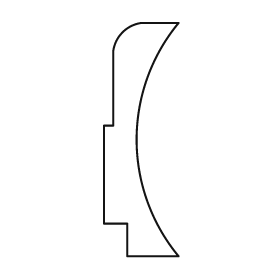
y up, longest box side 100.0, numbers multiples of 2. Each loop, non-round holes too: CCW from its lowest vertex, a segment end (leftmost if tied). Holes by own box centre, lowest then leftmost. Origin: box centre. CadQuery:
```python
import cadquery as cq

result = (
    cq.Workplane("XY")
    .moveTo(-6.0, -50.0)
    .lineTo(16.0, -50.0)
    .threePointArc((-2.0, 0.0), (16.0, 50.0))
    .lineTo(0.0, 50.0)
    .threePointArc((-8.0, 46.0), (-12.0, 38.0))
    .lineTo(-12.0, 6.0)
    .lineTo(-16.0, 6.0)
    .lineTo(-16.0, -36.0)
    .lineTo(-6.0, -36.0)
    .close()
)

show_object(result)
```